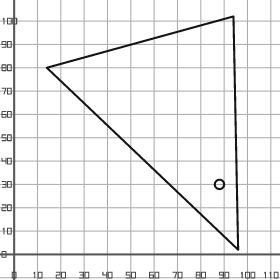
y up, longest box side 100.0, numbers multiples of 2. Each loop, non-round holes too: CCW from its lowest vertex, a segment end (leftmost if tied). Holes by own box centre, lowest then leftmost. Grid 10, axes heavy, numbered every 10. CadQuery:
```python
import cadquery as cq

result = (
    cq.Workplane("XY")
    .moveTo(96.0, 2.0)
    .lineTo(94.0, 102.0)
    .lineTo(14.0, 80.0)
    .close()
    .moveTo(88.0, 30.0)
    .circle(2.0)
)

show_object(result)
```